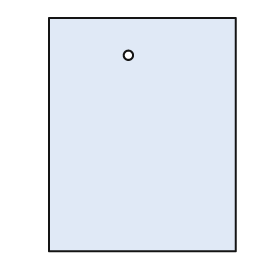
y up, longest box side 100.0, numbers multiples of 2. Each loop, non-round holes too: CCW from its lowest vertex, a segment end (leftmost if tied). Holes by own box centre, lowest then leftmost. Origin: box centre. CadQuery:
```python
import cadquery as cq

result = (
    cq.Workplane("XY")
    .moveTo(-40.0, -50.0)
    .lineTo(40.0, -50.0)
    .lineTo(40.0, 50.0)
    .lineTo(-40.0, 50.0)
    .close()
    .moveTo(-6.0, 34.0)
    .circle(2.0)
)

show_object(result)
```